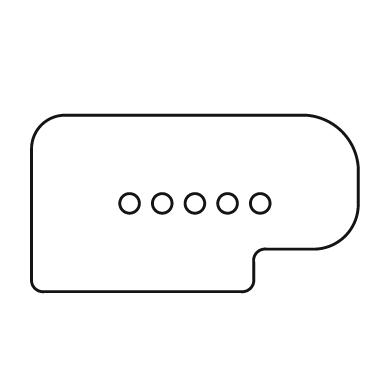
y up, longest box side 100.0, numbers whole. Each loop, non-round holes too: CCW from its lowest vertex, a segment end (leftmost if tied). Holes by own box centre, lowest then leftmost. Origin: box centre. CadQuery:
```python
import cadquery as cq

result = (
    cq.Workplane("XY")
    .moveTo(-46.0, -27.0)
    .lineTo(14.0, -27.0)
    .threePointArc((17.0, -26.0), (18.0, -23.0))
    .lineTo(18.0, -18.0)
    .threePointArc((19.0, -15.0), (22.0, -14.0))
    .lineTo(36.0, -14.0)
    .threePointArc((46.0, -10.0), (50.0, 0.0))
    .lineTo(50.0, 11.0)
    .threePointArc((45.0, 22.0), (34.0, 27.0))
    .lineTo(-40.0, 27.0)
    .threePointArc((-47.0, 24.0), (-50.0, 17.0))
    .lineTo(-50.0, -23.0)
    .threePointArc((-49.0, -26.0), (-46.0, -27.0))
    .close()
    .moveTo(-20.0, 0.0)
    .circle(3.0)
    .moveTo(-10.0, 0.0)
    .circle(3.0)
    .moveTo(0.0, 0.0)
    .circle(3.0)
    .moveTo(10.0, 0.0)
    .circle(3.0)
    .moveTo(20.0, 0.0)
    .circle(3.0)
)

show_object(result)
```